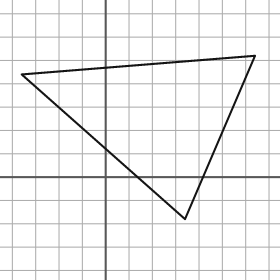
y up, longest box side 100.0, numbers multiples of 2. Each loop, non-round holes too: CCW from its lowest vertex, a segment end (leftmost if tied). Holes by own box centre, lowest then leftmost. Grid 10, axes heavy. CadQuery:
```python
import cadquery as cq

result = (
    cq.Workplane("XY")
    .moveTo(34.0, -18.0)
    .lineTo(64.0, 52.0)
    .lineTo(-36.0, 44.0)
    .close()
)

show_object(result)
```